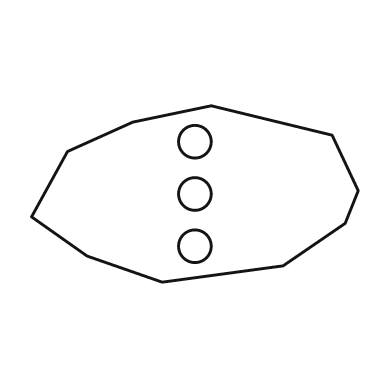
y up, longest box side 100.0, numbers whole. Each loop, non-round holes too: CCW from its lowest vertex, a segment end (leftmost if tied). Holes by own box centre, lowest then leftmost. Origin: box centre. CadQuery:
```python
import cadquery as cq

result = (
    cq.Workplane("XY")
    .moveTo(-10.0, -27.0)
    .lineTo(27.0, -22.0)
    .lineTo(46.0, -9.0)
    .lineTo(50.0, 1.0)
    .lineTo(42.0, 18.0)
    .lineTo(5.0, 27.0)
    .lineTo(-19.0, 22.0)
    .lineTo(-39.0, 13.0)
    .lineTo(-50.0, -7.0)
    .lineTo(-33.0, -19.0)
    .close()
    .moveTo(0.0, -16.0)
    .circle(5.0)
    .moveTo(0.0, 0.0)
    .circle(5.0)
    .moveTo(0.0, 16.0)
    .circle(5.0)
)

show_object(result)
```